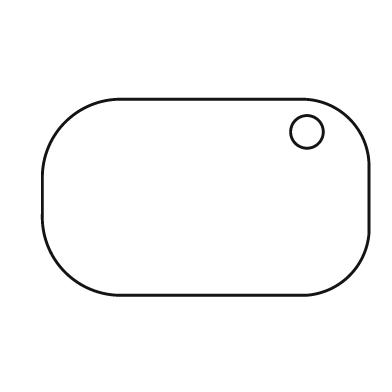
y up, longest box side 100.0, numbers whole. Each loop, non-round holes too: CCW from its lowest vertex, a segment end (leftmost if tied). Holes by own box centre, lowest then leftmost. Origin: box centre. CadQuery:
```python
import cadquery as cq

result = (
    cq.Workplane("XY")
    .moveTo(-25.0, -30.0)
    .lineTo(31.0, -30.0)
    .threePointArc((44.0, -24.0), (50.0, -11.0))
    .lineTo(50.0, 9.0)
    .threePointArc((44.0, 24.0), (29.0, 30.0))
    .lineTo(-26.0, 30.0)
    .threePointArc((-43.0, 23.0), (-50.0, 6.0))
    .lineTo(-50.0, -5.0)
    .threePointArc((-43.0, -23.0), (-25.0, -30.0))
    .close()
    .moveTo(31.0, 20.0)
    .circle(5.0)
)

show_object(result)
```